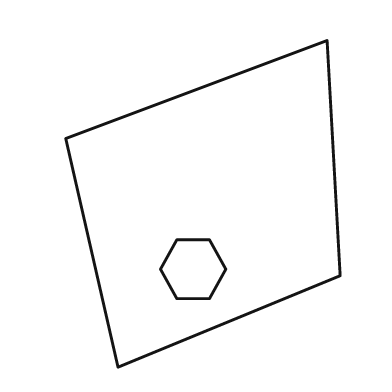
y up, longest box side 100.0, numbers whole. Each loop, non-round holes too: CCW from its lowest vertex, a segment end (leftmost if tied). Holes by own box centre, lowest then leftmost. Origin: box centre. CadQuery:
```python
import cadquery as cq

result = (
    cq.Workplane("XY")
    .moveTo(-26.0, -50.0)
    .lineTo(42.0, -22.0)
    .lineTo(38.0, 50.0)
    .lineTo(-42.0, 20.0)
    .close()
    .moveTo(-8.0, -29.0)
    .lineTo(2.0, -29.0)
    .lineTo(7.0, -20.0)
    .lineTo(2.0, -11.0)
    .lineTo(-8.0, -11.0)
    .lineTo(-13.0, -20.0)
    .close()
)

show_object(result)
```